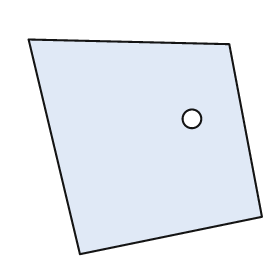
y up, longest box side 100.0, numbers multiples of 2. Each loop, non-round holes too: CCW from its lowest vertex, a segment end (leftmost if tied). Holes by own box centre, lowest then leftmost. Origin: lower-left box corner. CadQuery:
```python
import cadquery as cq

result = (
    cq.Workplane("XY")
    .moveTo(22.0, 0.0)
    .lineTo(100.0, 16.0)
    .lineTo(86.0, 90.0)
    .lineTo(0.0, 92.0)
    .close()
    .moveTo(70.0, 58.0)
    .circle(4.0)
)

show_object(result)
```